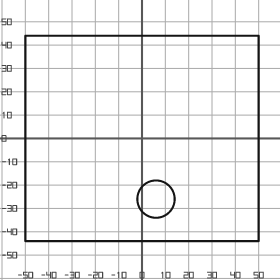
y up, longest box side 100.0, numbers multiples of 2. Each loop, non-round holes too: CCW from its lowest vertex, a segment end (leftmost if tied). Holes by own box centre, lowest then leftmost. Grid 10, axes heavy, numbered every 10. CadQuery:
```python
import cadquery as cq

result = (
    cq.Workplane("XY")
    .moveTo(-50.0, -44.0)
    .lineTo(50.0, -44.0)
    .lineTo(50.0, 44.0)
    .lineTo(-50.0, 44.0)
    .close()
    .moveTo(6.0, -26.0)
    .circle(8.0)
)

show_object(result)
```